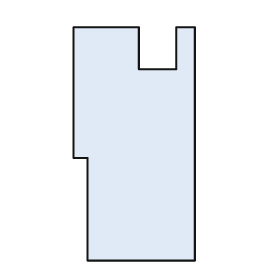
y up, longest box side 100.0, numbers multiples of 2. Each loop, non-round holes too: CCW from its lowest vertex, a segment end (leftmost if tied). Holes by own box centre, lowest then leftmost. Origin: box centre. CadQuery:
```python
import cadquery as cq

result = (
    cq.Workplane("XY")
    .moveTo(-20.0, -50.0)
    .lineTo(26.0, -50.0)
    .lineTo(26.0, 50.0)
    .lineTo(18.0, 50.0)
    .lineTo(18.0, 32.0)
    .lineTo(2.0, 32.0)
    .lineTo(2.0, 50.0)
    .lineTo(-26.0, 50.0)
    .lineTo(-26.0, -6.0)
    .lineTo(-20.0, -6.0)
    .close()
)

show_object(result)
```